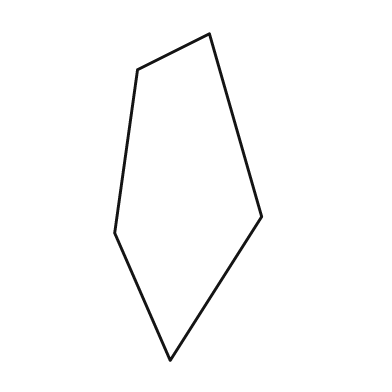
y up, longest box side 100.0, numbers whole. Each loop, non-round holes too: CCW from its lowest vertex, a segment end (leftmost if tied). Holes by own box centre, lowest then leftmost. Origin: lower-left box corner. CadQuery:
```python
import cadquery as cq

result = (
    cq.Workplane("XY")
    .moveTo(17.0, 0.0)
    .lineTo(45.0, 44.0)
    .lineTo(29.0, 100.0)
    .lineTo(7.0, 89.0)
    .lineTo(0.0, 39.0)
    .close()
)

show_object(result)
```